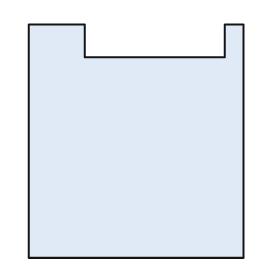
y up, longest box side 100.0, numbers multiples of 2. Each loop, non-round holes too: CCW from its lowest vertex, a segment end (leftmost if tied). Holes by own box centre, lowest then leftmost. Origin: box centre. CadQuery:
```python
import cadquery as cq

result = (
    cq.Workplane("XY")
    .moveTo(-46.0, -50.0)
    .lineTo(46.0, -50.0)
    .lineTo(46.0, 50.0)
    .lineTo(38.0, 50.0)
    .lineTo(38.0, 36.0)
    .lineTo(-22.0, 36.0)
    .lineTo(-22.0, 50.0)
    .lineTo(-46.0, 50.0)
    .close()
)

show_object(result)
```